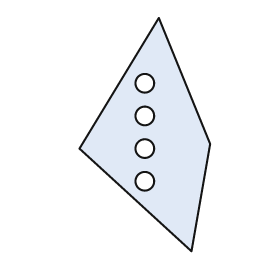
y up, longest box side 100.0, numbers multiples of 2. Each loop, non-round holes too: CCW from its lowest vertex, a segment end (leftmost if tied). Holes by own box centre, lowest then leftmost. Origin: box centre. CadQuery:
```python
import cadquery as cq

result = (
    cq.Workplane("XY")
    .moveTo(20.0, -50.0)
    .lineTo(28.0, -4.0)
    .lineTo(6.0, 50.0)
    .lineTo(-28.0, -6.0)
    .close()
    .moveTo(0.0, -20.0)
    .circle(4.0)
    .moveTo(0.0, -6.0)
    .circle(4.0)
    .moveTo(0.0, 8.0)
    .circle(4.0)
    .moveTo(0.0, 22.0)
    .circle(4.0)
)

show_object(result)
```